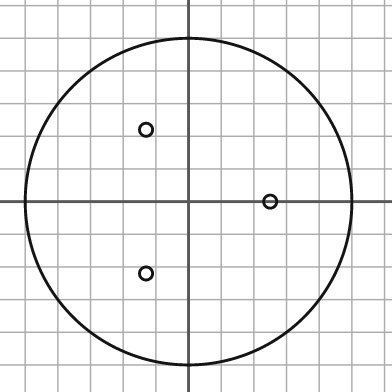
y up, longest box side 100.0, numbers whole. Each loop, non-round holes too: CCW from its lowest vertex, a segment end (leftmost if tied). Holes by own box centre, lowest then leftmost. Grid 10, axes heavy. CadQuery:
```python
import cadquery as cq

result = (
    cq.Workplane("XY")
    .moveTo(0.0, 0.0)
    .circle(50.0)
    .moveTo(-13.0, -22.0)
    .circle(2.0)
    .moveTo(25.0, 0.0)
    .circle(2.0)
    .moveTo(-13.0, 22.0)
    .circle(2.0)
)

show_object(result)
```